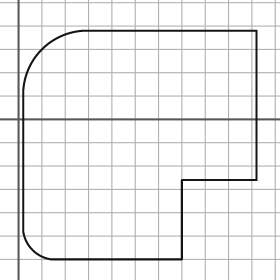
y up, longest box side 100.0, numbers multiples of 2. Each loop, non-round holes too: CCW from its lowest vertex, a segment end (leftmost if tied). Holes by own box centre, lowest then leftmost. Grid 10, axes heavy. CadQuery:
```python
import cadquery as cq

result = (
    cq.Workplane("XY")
    .moveTo(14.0, -60.0)
    .lineTo(70.0, -60.0)
    .lineTo(70.0, -26.0)
    .lineTo(102.0, -26.0)
    .lineTo(102.0, 38.0)
    .lineTo(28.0, 38.0)
    .threePointArc((10.0, 30.0), (2.0, 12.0))
    .lineTo(2.0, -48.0)
    .threePointArc((6.0, -56.0), (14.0, -60.0))
    .close()
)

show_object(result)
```